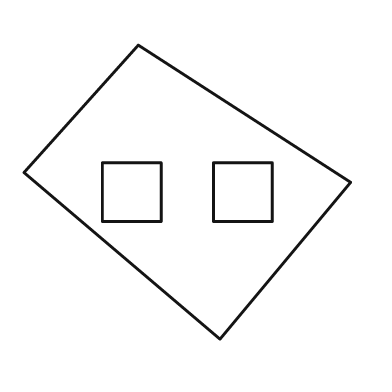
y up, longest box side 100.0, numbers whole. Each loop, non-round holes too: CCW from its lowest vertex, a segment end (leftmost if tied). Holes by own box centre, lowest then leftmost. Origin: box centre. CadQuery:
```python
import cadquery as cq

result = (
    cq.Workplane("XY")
    .moveTo(10.0, -45.0)
    .lineTo(50.0, 3.0)
    .lineTo(-15.0, 45.0)
    .lineTo(-50.0, 6.0)
    .close()
    .moveTo(-26.0, -9.0)
    .lineTo(-8.0, -9.0)
    .lineTo(-8.0, 9.0)
    .lineTo(-26.0, 9.0)
    .close()
    .moveTo(8.0, -9.0)
    .lineTo(26.0, -9.0)
    .lineTo(26.0, 9.0)
    .lineTo(8.0, 9.0)
    .close()
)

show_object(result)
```